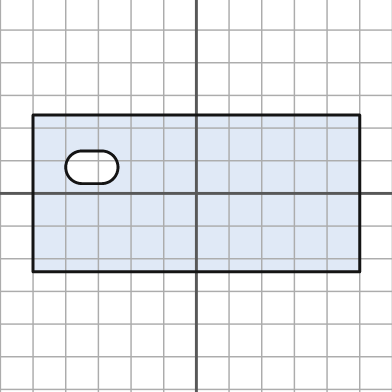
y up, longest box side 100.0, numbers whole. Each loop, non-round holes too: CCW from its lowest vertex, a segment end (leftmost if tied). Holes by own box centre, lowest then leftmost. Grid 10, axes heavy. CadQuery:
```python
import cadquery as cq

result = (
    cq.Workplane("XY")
    .moveTo(-50.0, -24.0)
    .lineTo(50.0, -24.0)
    .lineTo(50.0, 24.0)
    .lineTo(-50.0, 24.0)
    .close()
    .moveTo(-35.0, 3.0)
    .lineTo(-29.0, 3.0)
    .threePointArc((-24.0, 8.0), (-29.0, 13.0))
    .lineTo(-35.0, 13.0)
    .threePointArc((-40.0, 8.0), (-35.0, 3.0))
    .close()
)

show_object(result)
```